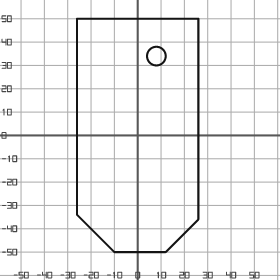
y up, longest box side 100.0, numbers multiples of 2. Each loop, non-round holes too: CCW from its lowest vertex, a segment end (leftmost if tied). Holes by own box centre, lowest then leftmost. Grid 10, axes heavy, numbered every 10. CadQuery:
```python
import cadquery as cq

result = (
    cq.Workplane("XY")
    .moveTo(-10.0, -50.0)
    .lineTo(12.0, -50.0)
    .lineTo(26.0, -36.0)
    .lineTo(26.0, 50.0)
    .lineTo(-26.0, 50.0)
    .lineTo(-26.0, -34.0)
    .close()
    .moveTo(8.0, 34.0)
    .circle(4.0)
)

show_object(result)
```